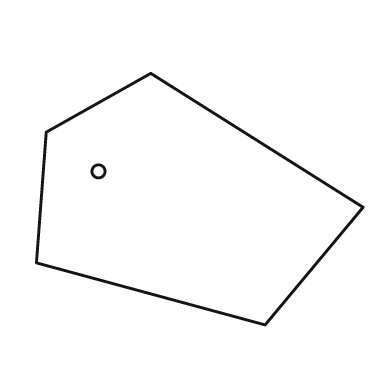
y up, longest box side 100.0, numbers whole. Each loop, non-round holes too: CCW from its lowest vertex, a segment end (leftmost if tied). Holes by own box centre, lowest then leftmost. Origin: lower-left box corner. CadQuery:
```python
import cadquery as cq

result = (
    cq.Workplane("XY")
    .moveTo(70.0, 0.0)
    .lineTo(100.0, 36.0)
    .lineTo(35.0, 77.0)
    .lineTo(3.0, 59.0)
    .lineTo(0.0, 19.0)
    .close()
    .moveTo(19.0, 47.0)
    .circle(2.0)
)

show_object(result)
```